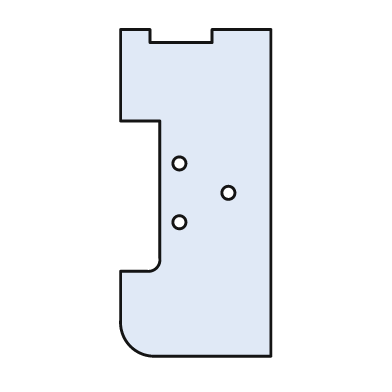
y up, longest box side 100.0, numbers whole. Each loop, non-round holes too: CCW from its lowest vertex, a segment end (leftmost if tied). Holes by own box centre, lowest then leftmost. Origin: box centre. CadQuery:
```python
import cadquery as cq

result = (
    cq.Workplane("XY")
    .moveTo(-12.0, -50.0)
    .lineTo(23.0, -50.0)
    .lineTo(23.0, 50.0)
    .lineTo(5.0, 50.0)
    .lineTo(5.0, 46.0)
    .lineTo(-14.0, 46.0)
    .lineTo(-14.0, 50.0)
    .lineTo(-23.0, 50.0)
    .lineTo(-23.0, 22.0)
    .lineTo(-11.0, 22.0)
    .lineTo(-11.0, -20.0)
    .threePointArc((-12.0, -23.0), (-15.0, -24.0))
    .lineTo(-23.0, -24.0)
    .lineTo(-23.0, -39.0)
    .threePointArc((-20.0, -47.0), (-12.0, -50.0))
    .close()
    .moveTo(-5.0, -9.0)
    .circle(2.0)
    .moveTo(10.0, 0.0)
    .circle(2.0)
    .moveTo(-5.0, 9.0)
    .circle(2.0)
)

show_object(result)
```